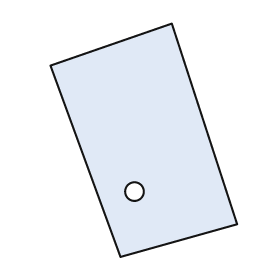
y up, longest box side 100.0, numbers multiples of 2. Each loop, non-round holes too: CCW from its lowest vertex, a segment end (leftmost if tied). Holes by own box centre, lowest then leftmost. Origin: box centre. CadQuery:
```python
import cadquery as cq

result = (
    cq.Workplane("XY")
    .moveTo(-10.0, -50.0)
    .lineTo(40.0, -36.0)
    .lineTo(12.0, 50.0)
    .lineTo(-40.0, 32.0)
    .close()
    .moveTo(-4.0, -22.0)
    .circle(4.0)
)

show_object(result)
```